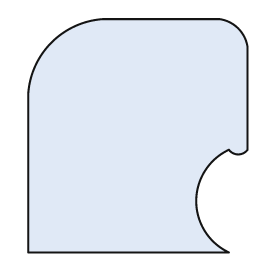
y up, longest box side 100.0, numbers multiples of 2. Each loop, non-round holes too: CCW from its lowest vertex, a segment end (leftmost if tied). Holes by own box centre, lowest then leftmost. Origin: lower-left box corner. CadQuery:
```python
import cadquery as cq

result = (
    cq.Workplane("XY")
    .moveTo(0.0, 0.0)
    .lineTo(86.0, 0.0)
    .threePointArc((72.0, 22.0), (86.0, 44.0))
    .threePointArc((90.0, 42.0), (94.0, 44.0))
    .lineTo(94.0, 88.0)
    .threePointArc((90.0, 96.0), (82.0, 100.0))
    .lineTo(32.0, 100.0)
    .threePointArc((10.0, 90.0), (0.0, 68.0))
    .close()
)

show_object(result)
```